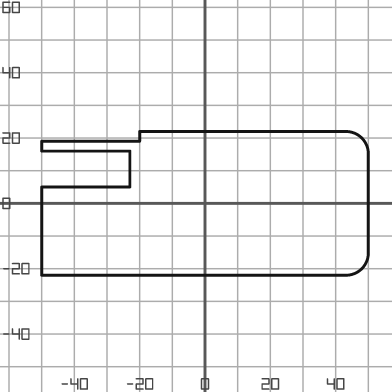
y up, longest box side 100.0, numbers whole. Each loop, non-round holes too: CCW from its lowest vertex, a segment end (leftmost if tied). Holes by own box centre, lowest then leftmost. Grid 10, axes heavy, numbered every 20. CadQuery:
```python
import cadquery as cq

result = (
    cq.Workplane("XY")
    .moveTo(-50.0, -22.0)
    .lineTo(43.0, -22.0)
    .threePointArc((48.0, -20.0), (50.0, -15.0))
    .lineTo(50.0, 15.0)
    .threePointArc((48.0, 20.0), (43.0, 22.0))
    .lineTo(-20.0, 22.0)
    .lineTo(-20.0, 19.0)
    .lineTo(-50.0, 19.0)
    .lineTo(-50.0, 16.0)
    .lineTo(-23.0, 16.0)
    .lineTo(-23.0, 5.0)
    .lineTo(-50.0, 5.0)
    .close()
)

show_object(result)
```